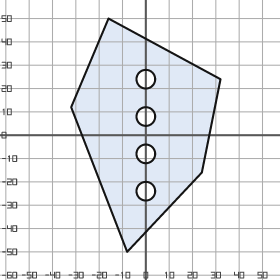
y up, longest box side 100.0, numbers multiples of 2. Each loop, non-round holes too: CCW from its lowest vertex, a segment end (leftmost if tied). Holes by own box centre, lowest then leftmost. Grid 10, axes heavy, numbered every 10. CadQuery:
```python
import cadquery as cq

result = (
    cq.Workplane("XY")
    .moveTo(-8.0, -50.0)
    .lineTo(24.0, -16.0)
    .lineTo(32.0, 24.0)
    .lineTo(-16.0, 50.0)
    .lineTo(-32.0, 12.0)
    .close()
    .moveTo(0.0, -24.0)
    .circle(4.0)
    .moveTo(0.0, -8.0)
    .circle(4.0)
    .moveTo(0.0, 8.0)
    .circle(4.0)
    .moveTo(0.0, 24.0)
    .circle(4.0)
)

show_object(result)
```